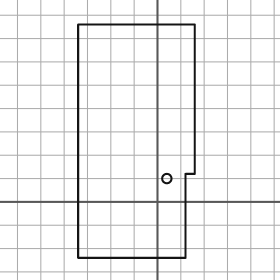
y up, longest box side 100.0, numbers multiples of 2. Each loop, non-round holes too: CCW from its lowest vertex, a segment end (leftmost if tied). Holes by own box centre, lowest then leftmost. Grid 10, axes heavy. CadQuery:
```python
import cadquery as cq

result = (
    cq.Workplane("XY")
    .moveTo(-34.0, -24.0)
    .lineTo(12.0, -24.0)
    .lineTo(12.0, 12.0)
    .lineTo(16.0, 12.0)
    .lineTo(16.0, 76.0)
    .lineTo(-34.0, 76.0)
    .close()
    .moveTo(4.0, 10.0)
    .circle(2.0)
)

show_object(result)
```